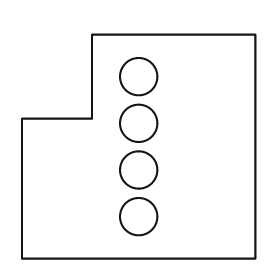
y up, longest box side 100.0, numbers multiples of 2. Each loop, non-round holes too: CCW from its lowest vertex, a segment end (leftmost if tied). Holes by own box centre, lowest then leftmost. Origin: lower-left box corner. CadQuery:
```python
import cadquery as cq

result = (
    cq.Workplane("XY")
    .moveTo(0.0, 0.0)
    .lineTo(100.0, 0.0)
    .lineTo(100.0, 96.0)
    .lineTo(30.0, 96.0)
    .lineTo(30.0, 60.0)
    .lineTo(0.0, 60.0)
    .close()
    .moveTo(50.0, 18.0)
    .circle(8.0)
    .moveTo(50.0, 38.0)
    .circle(8.0)
    .moveTo(50.0, 58.0)
    .circle(8.0)
    .moveTo(50.0, 78.0)
    .circle(8.0)
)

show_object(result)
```